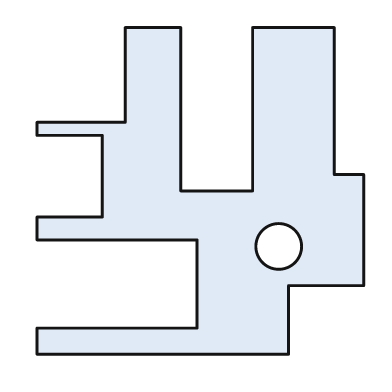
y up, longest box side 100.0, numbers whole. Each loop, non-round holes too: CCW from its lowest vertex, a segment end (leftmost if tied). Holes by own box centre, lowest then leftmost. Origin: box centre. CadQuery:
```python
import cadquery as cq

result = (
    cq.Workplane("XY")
    .moveTo(-50.0, -50.0)
    .lineTo(27.0, -50.0)
    .lineTo(27.0, -29.0)
    .lineTo(50.0, -29.0)
    .lineTo(50.0, 5.0)
    .lineTo(41.0, 5.0)
    .lineTo(41.0, 50.0)
    .lineTo(16.0, 50.0)
    .lineTo(16.0, 0.0)
    .lineTo(-6.0, 0.0)
    .lineTo(-6.0, 50.0)
    .lineTo(-23.0, 50.0)
    .lineTo(-23.0, 21.0)
    .lineTo(-50.0, 21.0)
    .lineTo(-50.0, 17.0)
    .lineTo(-30.0, 17.0)
    .lineTo(-30.0, -8.0)
    .lineTo(-50.0, -8.0)
    .lineTo(-50.0, -15.0)
    .lineTo(-1.0, -15.0)
    .lineTo(-1.0, -42.0)
    .lineTo(-50.0, -42.0)
    .close()
    .moveTo(24.0, -17.0)
    .circle(7.0)
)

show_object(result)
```